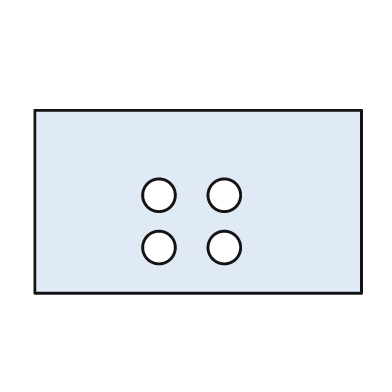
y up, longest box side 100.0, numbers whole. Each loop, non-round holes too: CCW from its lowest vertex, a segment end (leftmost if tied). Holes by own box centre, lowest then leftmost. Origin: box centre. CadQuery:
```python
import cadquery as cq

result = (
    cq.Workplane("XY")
    .moveTo(-50.0, -28.0)
    .lineTo(50.0, -28.0)
    .lineTo(50.0, 28.0)
    .lineTo(-50.0, 28.0)
    .close()
    .moveTo(-12.0, -14.0)
    .circle(5.0)
    .moveTo(8.0, -14.0)
    .circle(5.0)
    .moveTo(-12.0, 2.0)
    .circle(5.0)
    .moveTo(8.0, 2.0)
    .circle(5.0)
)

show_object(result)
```